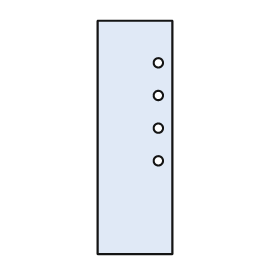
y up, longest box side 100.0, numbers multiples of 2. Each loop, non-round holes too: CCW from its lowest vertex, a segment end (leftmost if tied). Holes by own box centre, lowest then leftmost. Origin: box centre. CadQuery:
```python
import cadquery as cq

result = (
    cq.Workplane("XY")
    .moveTo(-16.0, -50.0)
    .lineTo(16.0, -50.0)
    .lineTo(16.0, 50.0)
    .lineTo(-16.0, 50.0)
    .close()
    .moveTo(10.0, -10.0)
    .circle(2.0)
    .moveTo(10.0, 4.0)
    .circle(2.0)
    .moveTo(10.0, 18.0)
    .circle(2.0)
    .moveTo(10.0, 32.0)
    .circle(2.0)
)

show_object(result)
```